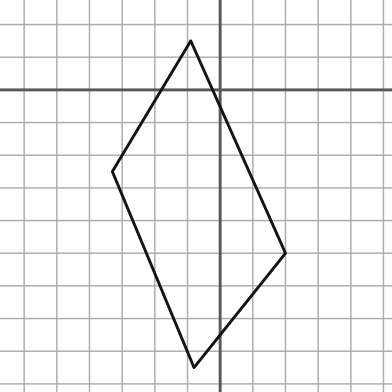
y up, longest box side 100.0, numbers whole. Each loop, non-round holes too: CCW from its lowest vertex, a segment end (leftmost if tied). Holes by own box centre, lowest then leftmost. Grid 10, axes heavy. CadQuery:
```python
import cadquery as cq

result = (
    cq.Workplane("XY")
    .moveTo(-8.0, -85.0)
    .lineTo(20.0, -50.0)
    .lineTo(-9.0, 15.0)
    .lineTo(-33.0, -25.0)
    .close()
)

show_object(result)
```